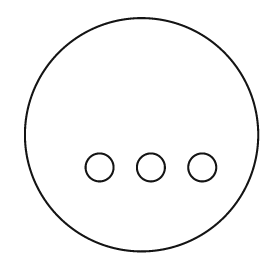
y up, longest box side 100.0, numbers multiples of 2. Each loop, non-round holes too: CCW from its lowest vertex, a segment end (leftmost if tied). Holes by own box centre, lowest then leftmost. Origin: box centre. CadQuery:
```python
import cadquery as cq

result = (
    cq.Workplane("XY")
    .moveTo(0.0, 0.0)
    .circle(50.0)
    .moveTo(-18.0, -14.0)
    .circle(6.0)
    .moveTo(4.0, -14.0)
    .circle(6.0)
    .moveTo(26.0, -14.0)
    .circle(6.0)
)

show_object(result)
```